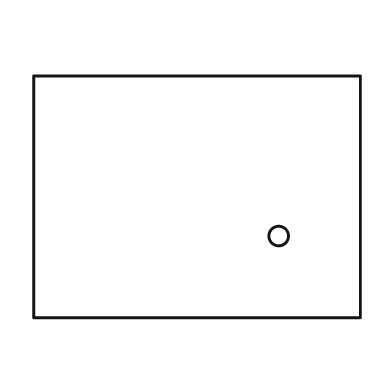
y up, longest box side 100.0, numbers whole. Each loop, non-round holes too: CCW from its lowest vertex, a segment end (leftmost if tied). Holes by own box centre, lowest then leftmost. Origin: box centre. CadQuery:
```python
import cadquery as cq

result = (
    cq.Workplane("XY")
    .moveTo(-50.0, -37.0)
    .lineTo(50.0, -37.0)
    .lineTo(50.0, 37.0)
    .lineTo(-50.0, 37.0)
    .close()
    .moveTo(25.0, -12.0)
    .circle(3.0)
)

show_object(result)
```